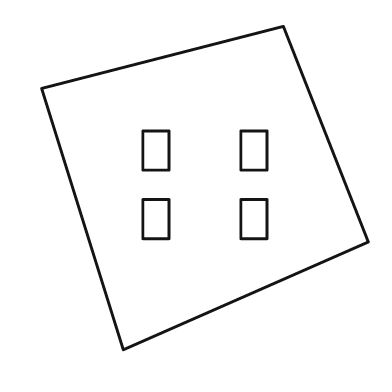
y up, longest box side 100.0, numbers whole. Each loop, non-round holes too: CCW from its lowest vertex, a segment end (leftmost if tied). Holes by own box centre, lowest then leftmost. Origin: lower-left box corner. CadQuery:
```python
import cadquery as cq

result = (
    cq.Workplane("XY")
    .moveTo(25.0, 0.0)
    .lineTo(100.0, 33.0)
    .lineTo(74.0, 99.0)
    .lineTo(0.0, 80.0)
    .close()
    .moveTo(31.0, 34.0)
    .lineTo(39.0, 34.0)
    .lineTo(39.0, 46.0)
    .lineTo(31.0, 46.0)
    .close()
    .moveTo(61.0, 34.0)
    .lineTo(69.0, 34.0)
    .lineTo(69.0, 46.0)
    .lineTo(61.0, 46.0)
    .close()
    .moveTo(31.0, 55.0)
    .lineTo(39.0, 55.0)
    .lineTo(39.0, 67.0)
    .lineTo(31.0, 67.0)
    .close()
    .moveTo(61.0, 55.0)
    .lineTo(69.0, 55.0)
    .lineTo(69.0, 67.0)
    .lineTo(61.0, 67.0)
    .close()
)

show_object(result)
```